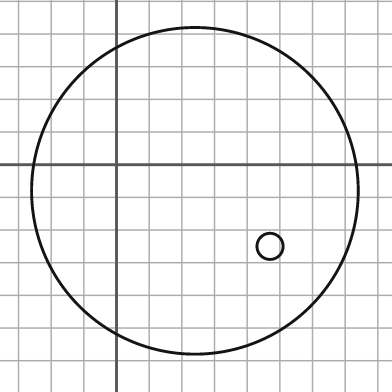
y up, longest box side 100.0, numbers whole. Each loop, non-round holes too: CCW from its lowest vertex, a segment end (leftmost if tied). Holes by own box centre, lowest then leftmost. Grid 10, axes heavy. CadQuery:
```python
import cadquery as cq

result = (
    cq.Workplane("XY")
    .moveTo(24.0, -8.0)
    .circle(50.0)
    .moveTo(47.0, -25.0)
    .circle(4.0)
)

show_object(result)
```